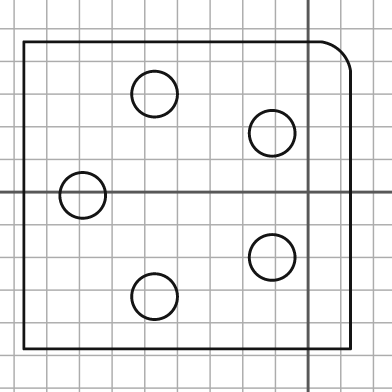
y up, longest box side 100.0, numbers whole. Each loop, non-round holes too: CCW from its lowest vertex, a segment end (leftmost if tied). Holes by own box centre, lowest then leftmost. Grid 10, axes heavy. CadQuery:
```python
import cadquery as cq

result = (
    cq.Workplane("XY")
    .moveTo(-87.0, -48.0)
    .lineTo(13.0, -48.0)
    .lineTo(13.0, 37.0)
    .threePointArc((10.0, 43.0), (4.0, 46.0))
    .lineTo(-87.0, 46.0)
    .close()
    .moveTo(-47.0, -32.0)
    .circle(7.0)
    .moveTo(-11.0, -20.0)
    .circle(7.0)
    .moveTo(-69.0, -1.0)
    .circle(7.0)
    .moveTo(-11.0, 18.0)
    .circle(7.0)
    .moveTo(-47.0, 30.0)
    .circle(7.0)
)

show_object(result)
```